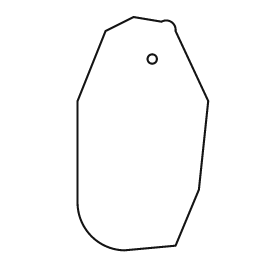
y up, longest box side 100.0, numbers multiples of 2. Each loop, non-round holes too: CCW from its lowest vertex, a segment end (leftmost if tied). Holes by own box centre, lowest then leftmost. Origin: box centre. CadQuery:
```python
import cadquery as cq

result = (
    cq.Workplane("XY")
    .moveTo(-8.0, -50.0)
    .lineTo(14.0, -48.0)
    .lineTo(24.0, -24.0)
    .lineTo(28.0, 14.0)
    .lineTo(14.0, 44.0)
    .threePointArc((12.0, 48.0), (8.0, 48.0))
    .lineTo(-4.0, 50.0)
    .lineTo(-16.0, 44.0)
    .lineTo(-28.0, 14.0)
    .lineTo(-28.0, -30.0)
    .threePointArc((-22.0, -44.0), (-8.0, -50.0))
    .close()
    .moveTo(4.0, 32.0)
    .circle(2.0)
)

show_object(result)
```